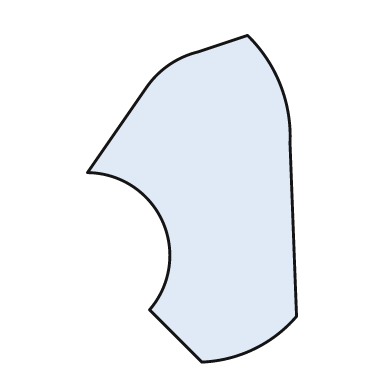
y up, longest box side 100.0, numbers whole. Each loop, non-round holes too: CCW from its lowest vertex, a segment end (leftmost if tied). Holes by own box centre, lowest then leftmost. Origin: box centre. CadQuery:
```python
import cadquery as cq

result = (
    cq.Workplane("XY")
    .moveTo(3.0, -50.0)
    .threePointArc((19.0, -46.0), (32.0, -36.0))
    .lineTo(30.0, 17.0)
    .threePointArc((27.0, 35.0), (17.0, 50.0))
    .lineTo(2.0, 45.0)
    .threePointArc((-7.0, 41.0), (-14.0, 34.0))
    .lineTo(-32.0, 8.0)
    .threePointArc((-9.0, -7.0), (-13.0, -34.0))
    .close()
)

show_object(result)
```